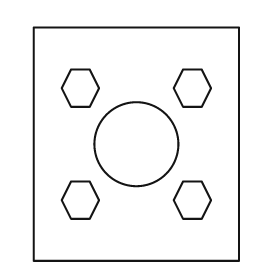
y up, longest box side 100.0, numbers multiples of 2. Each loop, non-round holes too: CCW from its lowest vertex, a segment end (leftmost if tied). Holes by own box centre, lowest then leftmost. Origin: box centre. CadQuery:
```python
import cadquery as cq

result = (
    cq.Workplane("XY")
    .moveTo(-44.0, -50.0)
    .lineTo(44.0, -50.0)
    .lineTo(44.0, 50.0)
    .lineTo(-44.0, 50.0)
    .close()
    .moveTo(-28.0, -32.0)
    .lineTo(-20.0, -32.0)
    .lineTo(-16.0, -24.0)
    .lineTo(-20.0, -16.0)
    .lineTo(-28.0, -16.0)
    .lineTo(-32.0, -24.0)
    .close()
    .moveTo(20.0, -32.0)
    .lineTo(28.0, -32.0)
    .lineTo(32.0, -24.0)
    .lineTo(28.0, -16.0)
    .lineTo(20.0, -16.0)
    .lineTo(16.0, -24.0)
    .close()
    .moveTo(0.0, 0.0)
    .circle(18.0)
    .moveTo(-28.0, 16.0)
    .lineTo(-20.0, 16.0)
    .lineTo(-16.0, 24.0)
    .lineTo(-20.0, 32.0)
    .lineTo(-28.0, 32.0)
    .lineTo(-32.0, 24.0)
    .close()
    .moveTo(20.0, 16.0)
    .lineTo(28.0, 16.0)
    .lineTo(32.0, 24.0)
    .lineTo(28.0, 32.0)
    .lineTo(20.0, 32.0)
    .lineTo(16.0, 24.0)
    .close()
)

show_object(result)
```